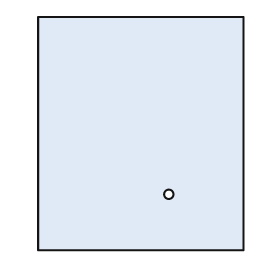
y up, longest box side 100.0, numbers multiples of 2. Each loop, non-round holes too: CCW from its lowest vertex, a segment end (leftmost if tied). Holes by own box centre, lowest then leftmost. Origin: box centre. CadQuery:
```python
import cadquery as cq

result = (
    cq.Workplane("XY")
    .moveTo(-44.0, -50.0)
    .lineTo(44.0, -50.0)
    .lineTo(44.0, 50.0)
    .lineTo(-44.0, 50.0)
    .close()
    .moveTo(12.0, -26.0)
    .circle(2.0)
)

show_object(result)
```